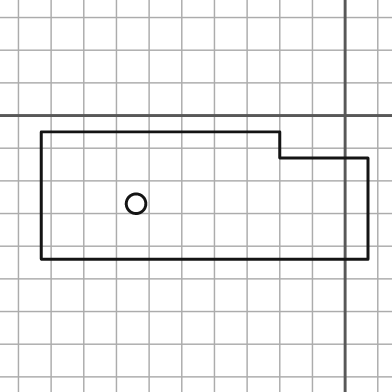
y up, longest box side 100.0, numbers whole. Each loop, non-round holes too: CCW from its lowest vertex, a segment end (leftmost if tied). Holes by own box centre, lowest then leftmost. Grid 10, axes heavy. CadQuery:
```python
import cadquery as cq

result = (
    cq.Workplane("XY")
    .moveTo(-93.0, -44.0)
    .lineTo(7.0, -44.0)
    .lineTo(7.0, -13.0)
    .lineTo(-20.0, -13.0)
    .lineTo(-20.0, -5.0)
    .lineTo(-93.0, -5.0)
    .close()
    .moveTo(-64.0, -27.0)
    .circle(3.0)
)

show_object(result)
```